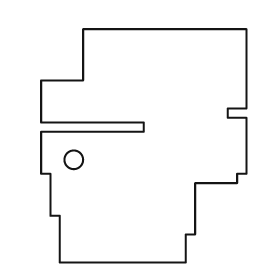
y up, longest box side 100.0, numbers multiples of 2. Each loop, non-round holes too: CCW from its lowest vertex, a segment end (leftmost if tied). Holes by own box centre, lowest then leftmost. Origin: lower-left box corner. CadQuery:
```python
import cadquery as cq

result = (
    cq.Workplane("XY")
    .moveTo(8.0, 0.0)
    .lineTo(62.0, 0.0)
    .lineTo(62.0, 12.0)
    .lineTo(66.0, 12.0)
    .lineTo(66.0, 34.0)
    .lineTo(84.0, 34.0)
    .lineTo(84.0, 38.0)
    .lineTo(88.0, 38.0)
    .lineTo(88.0, 62.0)
    .lineTo(80.0, 62.0)
    .lineTo(80.0, 66.0)
    .lineTo(88.0, 66.0)
    .lineTo(88.0, 100.0)
    .lineTo(18.0, 100.0)
    .lineTo(18.0, 78.0)
    .lineTo(0.0, 78.0)
    .lineTo(0.0, 60.0)
    .lineTo(44.0, 60.0)
    .lineTo(44.0, 56.0)
    .lineTo(0.0, 56.0)
    .lineTo(0.0, 38.0)
    .lineTo(4.0, 38.0)
    .lineTo(4.0, 20.0)
    .lineTo(8.0, 20.0)
    .close()
    .moveTo(14.0, 44.0)
    .circle(4.0)
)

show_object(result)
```